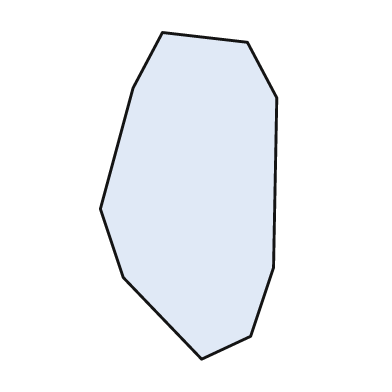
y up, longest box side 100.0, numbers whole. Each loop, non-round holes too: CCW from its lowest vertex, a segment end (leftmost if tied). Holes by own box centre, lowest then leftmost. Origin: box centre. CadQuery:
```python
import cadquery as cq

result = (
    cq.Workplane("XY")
    .moveTo(4.0, -50.0)
    .lineTo(19.0, -43.0)
    .lineTo(26.0, -22.0)
    .lineTo(27.0, 30.0)
    .lineTo(18.0, 47.0)
    .lineTo(-8.0, 50.0)
    .lineTo(-17.0, 33.0)
    .lineTo(-27.0, -4.0)
    .lineTo(-20.0, -25.0)
    .close()
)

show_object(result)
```